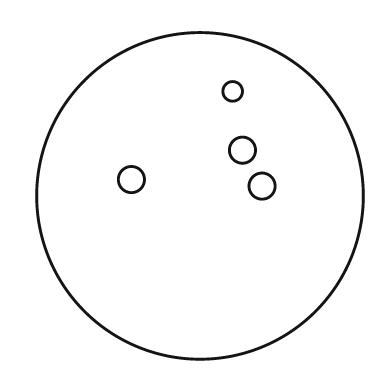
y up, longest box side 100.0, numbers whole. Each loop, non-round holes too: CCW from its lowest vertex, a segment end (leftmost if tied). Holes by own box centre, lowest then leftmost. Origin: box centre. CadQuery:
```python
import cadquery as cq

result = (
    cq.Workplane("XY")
    .moveTo(0.0, 0.0)
    .circle(50.0)
    .moveTo(19.0, 3.0)
    .circle(4.0)
    .moveTo(-21.0, 5.0)
    .circle(4.0)
    .moveTo(13.0, 14.0)
    .circle(4.0)
    .moveTo(10.0, 32.0)
    .circle(3.0)
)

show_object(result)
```